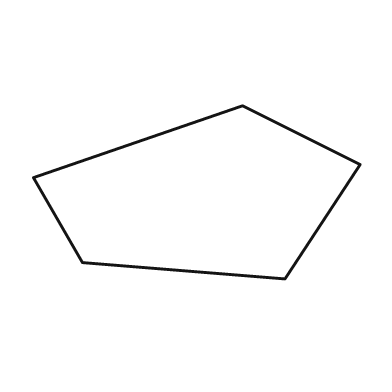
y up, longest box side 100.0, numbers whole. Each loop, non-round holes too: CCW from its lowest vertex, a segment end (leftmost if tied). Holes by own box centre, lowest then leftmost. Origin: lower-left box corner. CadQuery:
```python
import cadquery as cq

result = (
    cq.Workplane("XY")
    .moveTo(77.0, 0.0)
    .lineTo(100.0, 35.0)
    .lineTo(64.0, 53.0)
    .lineTo(0.0, 31.0)
    .lineTo(15.0, 5.0)
    .close()
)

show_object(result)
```